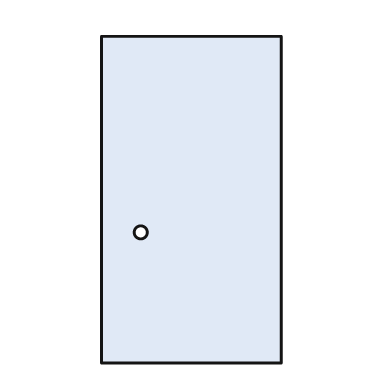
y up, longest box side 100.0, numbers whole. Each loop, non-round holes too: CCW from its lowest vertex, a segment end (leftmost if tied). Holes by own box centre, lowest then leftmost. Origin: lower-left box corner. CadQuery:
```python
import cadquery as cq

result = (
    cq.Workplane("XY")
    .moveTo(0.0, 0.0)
    .lineTo(55.0, 0.0)
    .lineTo(55.0, 100.0)
    .lineTo(0.0, 100.0)
    .close()
    .moveTo(12.0, 40.0)
    .circle(2.0)
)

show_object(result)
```